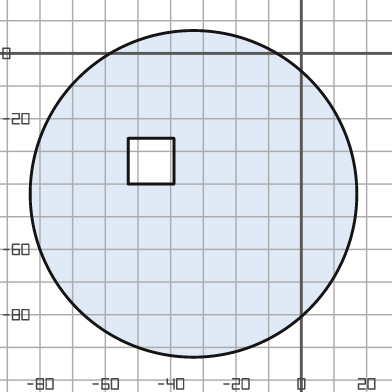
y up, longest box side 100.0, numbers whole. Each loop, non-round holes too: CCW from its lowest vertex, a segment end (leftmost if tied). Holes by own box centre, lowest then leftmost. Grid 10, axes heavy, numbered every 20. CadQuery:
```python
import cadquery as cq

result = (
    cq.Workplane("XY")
    .moveTo(-33.0, -43.0)
    .circle(50.0)
    .moveTo(-53.0, -40.0)
    .lineTo(-39.0, -40.0)
    .lineTo(-39.0, -26.0)
    .lineTo(-53.0, -26.0)
    .close()
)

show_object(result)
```